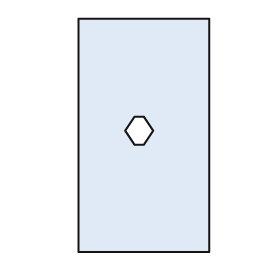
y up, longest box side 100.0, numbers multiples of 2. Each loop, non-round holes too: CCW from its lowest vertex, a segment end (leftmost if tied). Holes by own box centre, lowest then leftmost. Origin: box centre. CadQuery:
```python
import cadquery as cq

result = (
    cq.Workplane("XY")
    .moveTo(-28.0, -50.0)
    .lineTo(28.0, -50.0)
    .lineTo(28.0, 50.0)
    .lineTo(-28.0, 50.0)
    .close()
    .moveTo(-4.0, -4.0)
    .lineTo(0.0, -4.0)
    .lineTo(4.0, 2.0)
    .lineTo(0.0, 8.0)
    .lineTo(-4.0, 8.0)
    .lineTo(-8.0, 2.0)
    .close()
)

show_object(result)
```